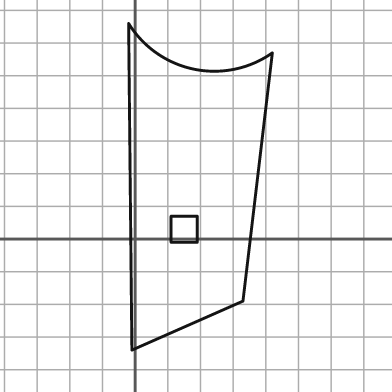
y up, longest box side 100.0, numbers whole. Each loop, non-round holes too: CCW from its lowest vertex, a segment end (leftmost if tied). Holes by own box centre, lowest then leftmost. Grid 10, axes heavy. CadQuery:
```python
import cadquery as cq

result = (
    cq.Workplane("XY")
    .moveTo(-1.0, -34.0)
    .lineTo(33.0, -19.0)
    .lineTo(42.0, 57.0)
    .threePointArc((18.0, 52.0), (-2.0, 66.0))
    .close()
    .moveTo(11.0, -1.0)
    .lineTo(19.0, -1.0)
    .lineTo(19.0, 7.0)
    .lineTo(11.0, 7.0)
    .close()
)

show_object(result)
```